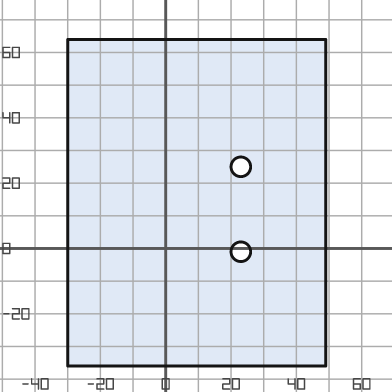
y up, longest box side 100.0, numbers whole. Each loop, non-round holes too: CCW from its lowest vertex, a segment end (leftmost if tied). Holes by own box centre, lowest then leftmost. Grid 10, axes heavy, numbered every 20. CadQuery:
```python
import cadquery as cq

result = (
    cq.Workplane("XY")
    .moveTo(-30.0, -36.0)
    .lineTo(49.0, -36.0)
    .lineTo(49.0, 64.0)
    .lineTo(-30.0, 64.0)
    .close()
    .moveTo(23.0, -1.0)
    .circle(3.0)
    .moveTo(23.0, 25.0)
    .circle(3.0)
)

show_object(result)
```